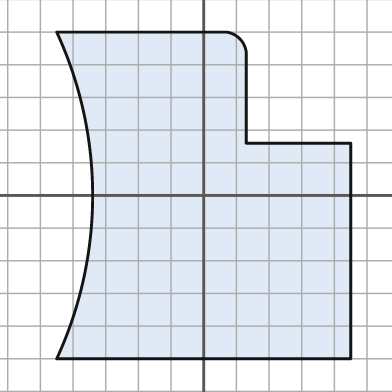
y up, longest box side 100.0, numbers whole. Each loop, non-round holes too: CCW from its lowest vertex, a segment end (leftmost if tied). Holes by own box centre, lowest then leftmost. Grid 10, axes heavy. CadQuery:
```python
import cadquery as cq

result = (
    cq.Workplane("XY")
    .moveTo(-45.0, -50.0)
    .lineTo(45.0, -50.0)
    .lineTo(45.0, 16.0)
    .lineTo(13.0, 16.0)
    .lineTo(13.0, 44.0)
    .threePointArc((11.0, 48.0), (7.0, 50.0))
    .lineTo(-45.0, 50.0)
    .threePointArc((-34.0, 0.0), (-45.0, -50.0))
    .close()
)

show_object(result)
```